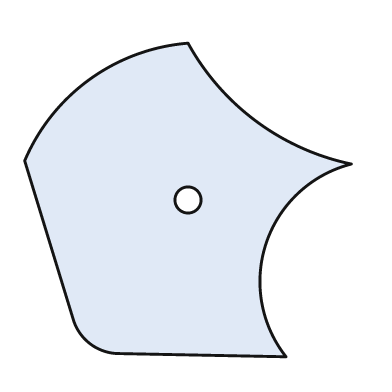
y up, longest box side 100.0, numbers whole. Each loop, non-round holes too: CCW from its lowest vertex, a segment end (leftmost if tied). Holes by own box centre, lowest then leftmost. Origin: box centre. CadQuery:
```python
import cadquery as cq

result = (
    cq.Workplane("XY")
    .moveTo(30.0, -48.0)
    .threePointArc((24.0, -13.0), (50.0, 11.0))
    .threePointArc((21.0, 24.0), (0.0, 48.0))
    .threePointArc((-30.0, 37.0), (-50.0, 12.0))
    .lineTo(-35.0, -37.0)
    .threePointArc((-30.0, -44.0), (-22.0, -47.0))
    .close()
    .moveTo(0.0, 0.0)
    .circle(4.0)
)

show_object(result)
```